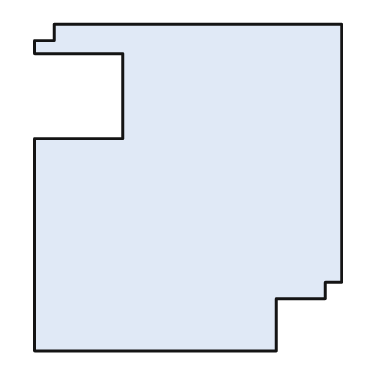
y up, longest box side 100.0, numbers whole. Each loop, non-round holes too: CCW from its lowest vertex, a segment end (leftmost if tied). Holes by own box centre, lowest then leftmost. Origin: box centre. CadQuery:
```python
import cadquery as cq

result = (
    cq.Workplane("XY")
    .moveTo(-47.0, -50.0)
    .lineTo(27.0, -50.0)
    .lineTo(27.0, -34.0)
    .lineTo(42.0, -34.0)
    .lineTo(42.0, -29.0)
    .lineTo(47.0, -29.0)
    .lineTo(47.0, 50.0)
    .lineTo(-41.0, 50.0)
    .lineTo(-41.0, 45.0)
    .lineTo(-47.0, 45.0)
    .lineTo(-47.0, 41.0)
    .lineTo(-20.0, 41.0)
    .lineTo(-20.0, 15.0)
    .lineTo(-47.0, 15.0)
    .close()
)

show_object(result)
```